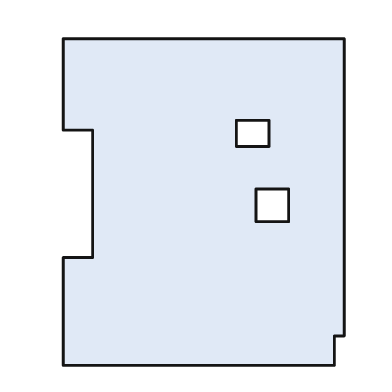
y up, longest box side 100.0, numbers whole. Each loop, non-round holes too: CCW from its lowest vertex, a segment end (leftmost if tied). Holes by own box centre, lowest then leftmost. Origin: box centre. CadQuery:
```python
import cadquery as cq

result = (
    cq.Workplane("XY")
    .moveTo(-43.0, -50.0)
    .lineTo(40.0, -50.0)
    .lineTo(40.0, -41.0)
    .lineTo(43.0, -41.0)
    .lineTo(43.0, 50.0)
    .lineTo(-43.0, 50.0)
    .lineTo(-43.0, 22.0)
    .lineTo(-34.0, 22.0)
    .lineTo(-34.0, -17.0)
    .lineTo(-43.0, -17.0)
    .close()
    .moveTo(16.0, -6.0)
    .lineTo(26.0, -6.0)
    .lineTo(26.0, 4.0)
    .lineTo(16.0, 4.0)
    .close()
    .moveTo(10.0, 17.0)
    .lineTo(20.0, 17.0)
    .lineTo(20.0, 25.0)
    .lineTo(10.0, 25.0)
    .close()
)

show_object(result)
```